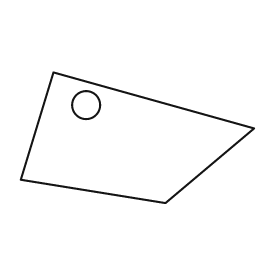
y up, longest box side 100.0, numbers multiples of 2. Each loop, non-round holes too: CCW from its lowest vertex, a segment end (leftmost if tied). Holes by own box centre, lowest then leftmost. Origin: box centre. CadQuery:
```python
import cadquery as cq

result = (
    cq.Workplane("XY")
    .moveTo(12.0, -28.0)
    .lineTo(50.0, 4.0)
    .lineTo(-36.0, 28.0)
    .lineTo(-50.0, -18.0)
    .close()
    .moveTo(-22.0, 14.0)
    .circle(6.0)
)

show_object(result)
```